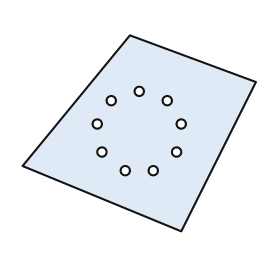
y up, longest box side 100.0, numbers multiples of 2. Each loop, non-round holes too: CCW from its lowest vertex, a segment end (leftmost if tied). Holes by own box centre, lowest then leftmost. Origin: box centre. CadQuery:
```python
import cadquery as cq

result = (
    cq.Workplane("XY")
    .moveTo(18.0, -42.0)
    .lineTo(50.0, 22.0)
    .lineTo(-4.0, 42.0)
    .lineTo(-50.0, -14.0)
    .close()
    .moveTo(-6.0, -16.0)
    .circle(2.0)
    .moveTo(6.0, -16.0)
    .circle(2.0)
    .moveTo(-16.0, -8.0)
    .circle(2.0)
    .moveTo(16.0, -8.0)
    .circle(2.0)
    .moveTo(-18.0, 4.0)
    .circle(2.0)
    .moveTo(18.0, 4.0)
    .circle(2.0)
    .moveTo(-12.0, 14.0)
    .circle(2.0)
    .moveTo(12.0, 14.0)
    .circle(2.0)
    .moveTo(0.0, 18.0)
    .circle(2.0)
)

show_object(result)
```